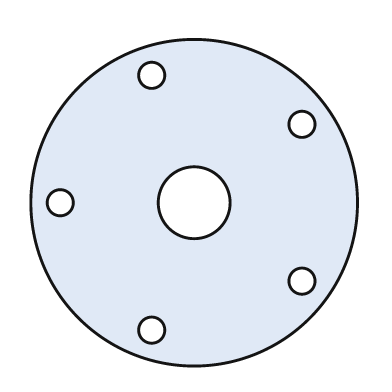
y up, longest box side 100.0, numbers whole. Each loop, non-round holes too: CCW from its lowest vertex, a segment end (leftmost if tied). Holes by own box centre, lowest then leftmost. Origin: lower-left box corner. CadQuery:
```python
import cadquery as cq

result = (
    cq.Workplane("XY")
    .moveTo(50.0, 50.0)
    .circle(50.0)
    .moveTo(37.0, 11.0)
    .circle(4.0)
    .moveTo(83.0, 26.0)
    .circle(4.0)
    .moveTo(9.0, 50.0)
    .circle(4.0)
    .moveTo(50.0, 50.0)
    .circle(11.0)
    .moveTo(83.0, 74.0)
    .circle(4.0)
    .moveTo(37.0, 89.0)
    .circle(4.0)
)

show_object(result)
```